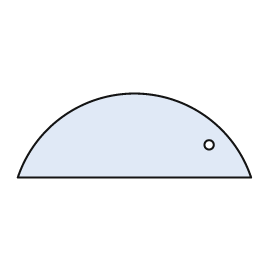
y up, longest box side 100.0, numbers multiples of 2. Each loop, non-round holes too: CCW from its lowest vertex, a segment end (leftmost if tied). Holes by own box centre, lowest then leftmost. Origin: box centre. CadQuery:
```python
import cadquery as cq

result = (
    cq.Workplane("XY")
    .moveTo(-50.0, -18.0)
    .lineTo(50.0, -18.0)
    .threePointArc((0.0, 18.0), (-50.0, -18.0))
    .close()
    .moveTo(32.0, -4.0)
    .circle(2.0)
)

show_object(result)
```